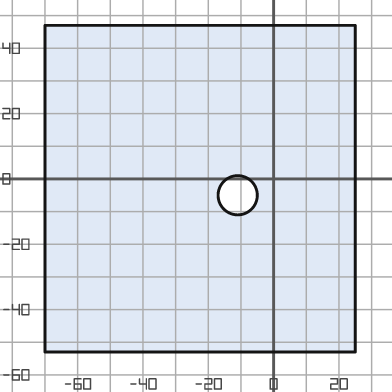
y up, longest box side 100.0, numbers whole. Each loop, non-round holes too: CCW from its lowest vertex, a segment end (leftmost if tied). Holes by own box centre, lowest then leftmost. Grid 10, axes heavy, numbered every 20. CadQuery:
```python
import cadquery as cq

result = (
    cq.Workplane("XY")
    .moveTo(-70.0, -53.0)
    .lineTo(25.0, -53.0)
    .lineTo(25.0, 47.0)
    .lineTo(-70.0, 47.0)
    .close()
    .moveTo(-11.0, -5.0)
    .circle(6.0)
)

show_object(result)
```